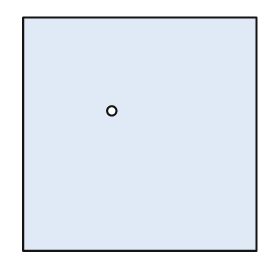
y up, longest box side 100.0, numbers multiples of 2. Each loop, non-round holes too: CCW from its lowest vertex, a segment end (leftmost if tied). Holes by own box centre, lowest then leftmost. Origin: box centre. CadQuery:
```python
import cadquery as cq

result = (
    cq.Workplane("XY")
    .moveTo(-50.0, -50.0)
    .lineTo(50.0, -50.0)
    .lineTo(50.0, 50.0)
    .lineTo(-50.0, 50.0)
    .close()
    .moveTo(-12.0, 10.0)
    .circle(2.0)
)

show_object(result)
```